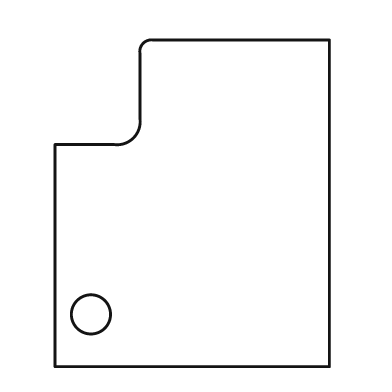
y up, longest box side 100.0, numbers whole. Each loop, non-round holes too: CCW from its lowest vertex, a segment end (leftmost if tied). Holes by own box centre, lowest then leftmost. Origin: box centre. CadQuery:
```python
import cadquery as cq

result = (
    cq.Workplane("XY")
    .moveTo(-42.0, -50.0)
    .lineTo(42.0, -50.0)
    .lineTo(42.0, 50.0)
    .lineTo(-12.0, 50.0)
    .threePointArc((-15.0, 49.0), (-16.0, 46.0))
    .lineTo(-16.0, 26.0)
    .threePointArc((-18.0, 20.0), (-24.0, 18.0))
    .lineTo(-42.0, 18.0)
    .close()
    .moveTo(-31.0, -34.0)
    .circle(6.0)
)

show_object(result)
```